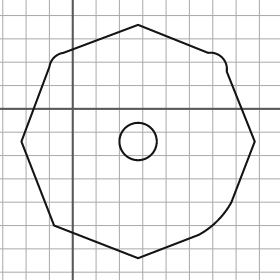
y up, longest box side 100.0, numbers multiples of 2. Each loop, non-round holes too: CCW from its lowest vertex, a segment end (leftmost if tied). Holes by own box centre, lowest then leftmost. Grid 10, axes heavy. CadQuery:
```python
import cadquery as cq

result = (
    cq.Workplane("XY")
    .moveTo(28.0, -64.0)
    .lineTo(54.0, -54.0)
    .threePointArc((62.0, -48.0), (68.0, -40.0))
    .lineTo(78.0, -14.0)
    .lineTo(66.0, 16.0)
    .threePointArc((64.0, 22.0), (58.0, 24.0))
    .lineTo(28.0, 36.0)
    .lineTo(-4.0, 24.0)
    .threePointArc((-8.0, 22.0), (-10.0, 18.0))
    .lineTo(-22.0, -14.0)
    .lineTo(-8.0, -50.0)
    .close()
    .moveTo(28.0, -14.0)
    .circle(8.0)
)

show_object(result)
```